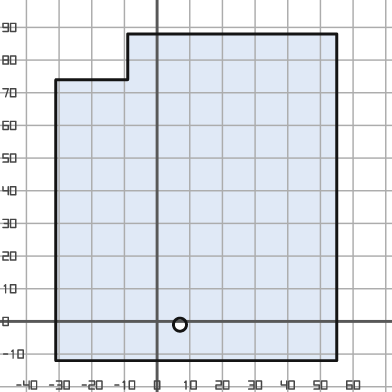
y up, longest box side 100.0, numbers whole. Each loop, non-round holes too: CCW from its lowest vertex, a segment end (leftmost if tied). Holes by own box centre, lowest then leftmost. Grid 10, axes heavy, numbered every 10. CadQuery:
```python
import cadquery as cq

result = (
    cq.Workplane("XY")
    .moveTo(-31.0, -12.0)
    .lineTo(55.0, -12.0)
    .lineTo(55.0, 88.0)
    .lineTo(-9.0, 88.0)
    .lineTo(-9.0, 74.0)
    .lineTo(-31.0, 74.0)
    .close()
    .moveTo(7.0, -1.0)
    .circle(2.0)
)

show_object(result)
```